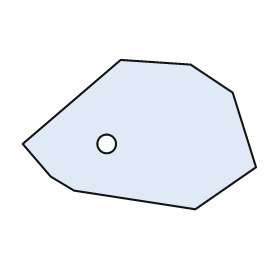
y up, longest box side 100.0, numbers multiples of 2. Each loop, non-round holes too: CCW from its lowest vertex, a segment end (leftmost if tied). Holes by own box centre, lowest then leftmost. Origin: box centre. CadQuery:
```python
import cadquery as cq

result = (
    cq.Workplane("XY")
    .moveTo(24.0, -32.0)
    .lineTo(50.0, -14.0)
    .lineTo(40.0, 18.0)
    .lineTo(22.0, 30.0)
    .lineTo(-8.0, 32.0)
    .lineTo(-50.0, -4.0)
    .lineTo(-38.0, -18.0)
    .lineTo(-28.0, -24.0)
    .close()
    .moveTo(-14.0, -4.0)
    .circle(4.0)
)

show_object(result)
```